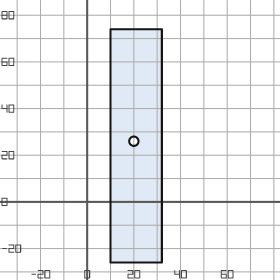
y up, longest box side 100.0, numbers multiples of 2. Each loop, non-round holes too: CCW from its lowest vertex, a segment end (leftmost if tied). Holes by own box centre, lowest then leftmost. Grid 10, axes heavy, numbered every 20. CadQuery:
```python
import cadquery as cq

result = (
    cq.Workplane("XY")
    .moveTo(10.0, -26.0)
    .lineTo(32.0, -26.0)
    .lineTo(32.0, 74.0)
    .lineTo(10.0, 74.0)
    .close()
    .moveTo(20.0, 26.0)
    .circle(2.0)
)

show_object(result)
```